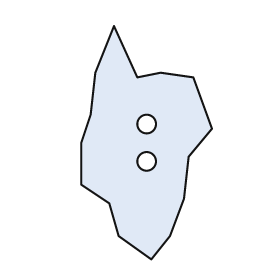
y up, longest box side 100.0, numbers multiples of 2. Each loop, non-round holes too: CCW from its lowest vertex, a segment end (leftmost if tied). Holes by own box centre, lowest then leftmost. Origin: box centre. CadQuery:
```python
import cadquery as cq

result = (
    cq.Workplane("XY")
    .moveTo(2.0, -50.0)
    .lineTo(10.0, -40.0)
    .lineTo(16.0, -24.0)
    .lineTo(18.0, -6.0)
    .lineTo(28.0, 6.0)
    .lineTo(20.0, 28.0)
    .lineTo(6.0, 30.0)
    .lineTo(-4.0, 28.0)
    .lineTo(-14.0, 50.0)
    .lineTo(-22.0, 30.0)
    .lineTo(-24.0, 12.0)
    .lineTo(-28.0, 0.0)
    .lineTo(-28.0, -18.0)
    .lineTo(-16.0, -26.0)
    .lineTo(-12.0, -40.0)
    .close()
    .moveTo(0.0, -8.0)
    .circle(4.0)
    .moveTo(0.0, 8.0)
    .circle(4.0)
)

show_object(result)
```